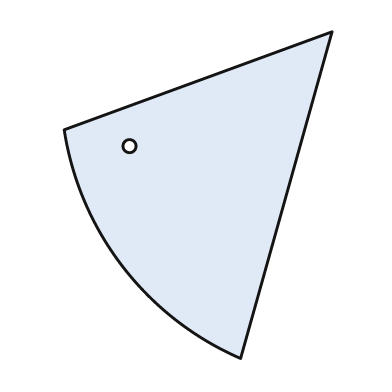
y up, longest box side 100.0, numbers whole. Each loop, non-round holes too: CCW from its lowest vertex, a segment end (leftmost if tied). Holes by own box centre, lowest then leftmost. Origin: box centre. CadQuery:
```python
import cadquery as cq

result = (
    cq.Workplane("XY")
    .moveTo(13.0, -50.0)
    .lineTo(41.0, 50.0)
    .lineTo(-41.0, 20.0)
    .threePointArc((-23.0, -22.0), (13.0, -50.0))
    .close()
    .moveTo(-21.0, 15.0)
    .circle(2.0)
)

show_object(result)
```